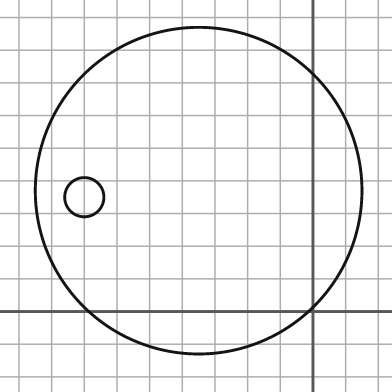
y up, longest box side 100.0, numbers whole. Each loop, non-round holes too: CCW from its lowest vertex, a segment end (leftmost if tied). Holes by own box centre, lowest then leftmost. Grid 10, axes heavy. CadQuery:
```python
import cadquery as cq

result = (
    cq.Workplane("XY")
    .moveTo(-35.0, 37.0)
    .circle(50.0)
    .moveTo(-70.0, 35.0)
    .circle(6.0)
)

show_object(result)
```